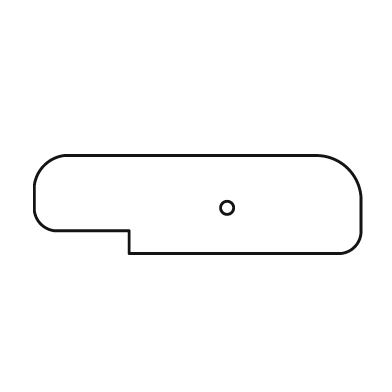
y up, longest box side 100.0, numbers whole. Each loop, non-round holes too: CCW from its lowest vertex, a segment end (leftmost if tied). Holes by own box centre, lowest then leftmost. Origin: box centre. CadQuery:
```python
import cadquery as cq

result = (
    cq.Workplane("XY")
    .moveTo(-21.0, -15.0)
    .lineTo(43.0, -15.0)
    .threePointArc((48.0, -13.0), (50.0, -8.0))
    .lineTo(50.0, 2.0)
    .threePointArc((46.0, 11.0), (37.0, 15.0))
    .lineTo(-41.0, 15.0)
    .threePointArc((-47.0, 12.0), (-50.0, 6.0))
    .lineTo(-50.0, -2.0)
    .threePointArc((-48.0, -6.0), (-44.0, -8.0))
    .lineTo(-21.0, -8.0)
    .close()
    .moveTo(9.0, -1.0)
    .circle(2.0)
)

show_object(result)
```